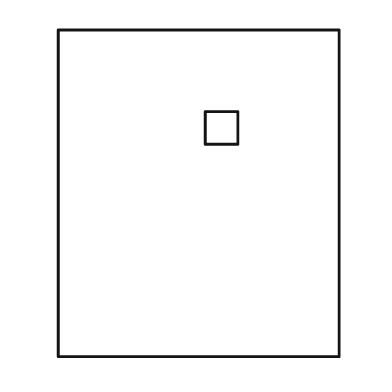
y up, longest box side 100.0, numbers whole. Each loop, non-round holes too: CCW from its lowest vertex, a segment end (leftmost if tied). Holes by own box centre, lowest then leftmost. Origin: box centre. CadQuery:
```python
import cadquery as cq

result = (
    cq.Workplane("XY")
    .moveTo(-43.0, -50.0)
    .lineTo(43.0, -50.0)
    .lineTo(43.0, 50.0)
    .lineTo(-43.0, 50.0)
    .close()
    .moveTo(2.0, 15.0)
    .lineTo(12.0, 15.0)
    .lineTo(12.0, 25.0)
    .lineTo(2.0, 25.0)
    .close()
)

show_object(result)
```